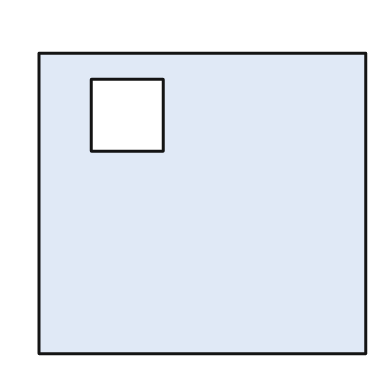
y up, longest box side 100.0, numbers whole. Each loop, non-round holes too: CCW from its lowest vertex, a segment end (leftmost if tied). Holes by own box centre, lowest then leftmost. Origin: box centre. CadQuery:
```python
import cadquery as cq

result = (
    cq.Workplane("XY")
    .moveTo(-50.0, -46.0)
    .lineTo(50.0, -46.0)
    .lineTo(50.0, 46.0)
    .lineTo(-50.0, 46.0)
    .close()
    .moveTo(-34.0, 16.0)
    .lineTo(-12.0, 16.0)
    .lineTo(-12.0, 38.0)
    .lineTo(-34.0, 38.0)
    .close()
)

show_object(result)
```